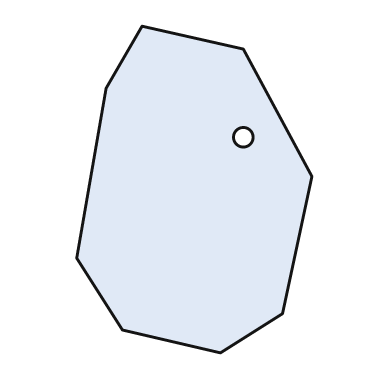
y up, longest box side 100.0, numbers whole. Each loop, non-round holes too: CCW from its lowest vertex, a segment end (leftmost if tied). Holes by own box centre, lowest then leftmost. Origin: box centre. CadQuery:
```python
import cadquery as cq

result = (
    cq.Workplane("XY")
    .moveTo(8.0, -50.0)
    .lineTo(27.0, -38.0)
    .lineTo(36.0, 4.0)
    .lineTo(15.0, 43.0)
    .lineTo(-16.0, 50.0)
    .lineTo(-27.0, 31.0)
    .lineTo(-36.0, -21.0)
    .lineTo(-22.0, -43.0)
    .close()
    .moveTo(15.0, 16.0)
    .circle(3.0)
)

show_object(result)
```